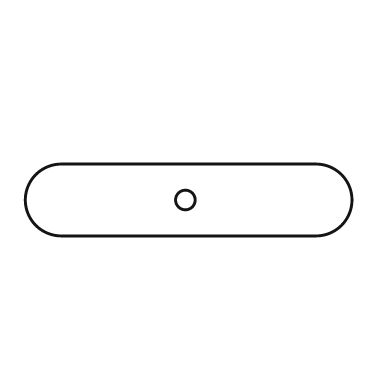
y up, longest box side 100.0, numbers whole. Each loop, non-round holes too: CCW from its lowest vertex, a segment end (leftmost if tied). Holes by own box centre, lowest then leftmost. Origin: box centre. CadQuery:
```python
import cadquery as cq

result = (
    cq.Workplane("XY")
    .moveTo(-39.0, -11.0)
    .lineTo(39.0, -11.0)
    .threePointArc((50.0, 0.0), (39.0, 11.0))
    .lineTo(-39.0, 11.0)
    .threePointArc((-50.0, 0.0), (-39.0, -11.0))
    .close()
    .moveTo(-1.0, 0.0)
    .circle(3.0)
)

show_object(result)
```